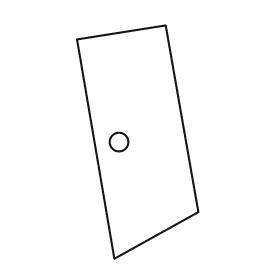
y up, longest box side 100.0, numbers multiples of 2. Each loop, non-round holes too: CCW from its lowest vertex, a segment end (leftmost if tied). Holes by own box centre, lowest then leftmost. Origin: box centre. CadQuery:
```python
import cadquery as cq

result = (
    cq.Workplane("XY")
    .moveTo(-10.0, -50.0)
    .lineTo(26.0, -30.0)
    .lineTo(12.0, 50.0)
    .lineTo(-26.0, 44.0)
    .close()
    .moveTo(-8.0, 0.0)
    .circle(4.0)
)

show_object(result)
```